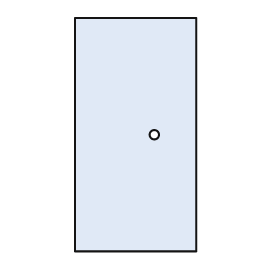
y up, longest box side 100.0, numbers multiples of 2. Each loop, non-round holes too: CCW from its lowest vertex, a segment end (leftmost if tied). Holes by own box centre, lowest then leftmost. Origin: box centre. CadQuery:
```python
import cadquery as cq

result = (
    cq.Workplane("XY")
    .moveTo(-26.0, -50.0)
    .lineTo(26.0, -50.0)
    .lineTo(26.0, 50.0)
    .lineTo(-26.0, 50.0)
    .close()
    .moveTo(8.0, 0.0)
    .circle(2.0)
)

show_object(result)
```